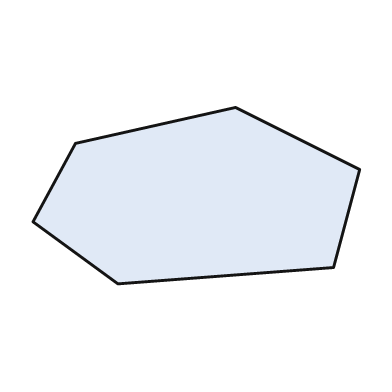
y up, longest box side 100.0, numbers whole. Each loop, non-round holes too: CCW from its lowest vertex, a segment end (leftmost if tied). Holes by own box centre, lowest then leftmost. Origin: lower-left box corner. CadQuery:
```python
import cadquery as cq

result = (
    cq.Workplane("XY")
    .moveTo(26.0, 0.0)
    .lineTo(92.0, 5.0)
    .lineTo(100.0, 35.0)
    .lineTo(62.0, 54.0)
    .lineTo(13.0, 43.0)
    .lineTo(0.0, 19.0)
    .close()
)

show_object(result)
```